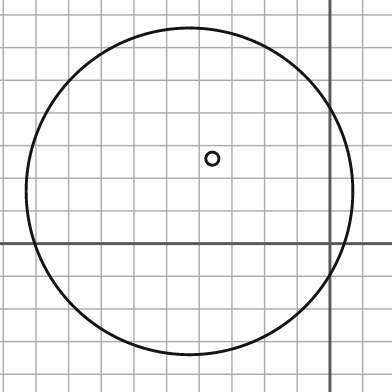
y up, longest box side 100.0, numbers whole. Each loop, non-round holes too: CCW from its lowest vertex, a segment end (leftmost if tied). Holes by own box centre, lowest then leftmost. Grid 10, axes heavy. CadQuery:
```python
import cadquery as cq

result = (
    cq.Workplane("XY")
    .moveTo(-43.0, 16.0)
    .circle(50.0)
    .moveTo(-36.0, 26.0)
    .circle(2.0)
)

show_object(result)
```